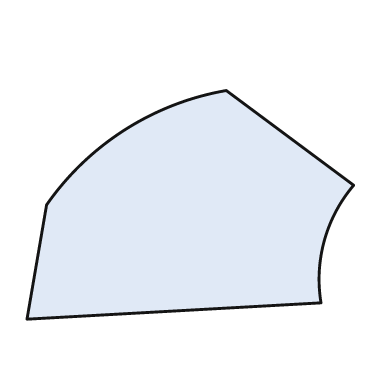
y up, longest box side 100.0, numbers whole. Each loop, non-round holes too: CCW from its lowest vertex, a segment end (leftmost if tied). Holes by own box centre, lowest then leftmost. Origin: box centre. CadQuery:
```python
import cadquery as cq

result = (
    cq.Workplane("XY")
    .moveTo(-50.0, -35.0)
    .lineTo(40.0, -30.0)
    .threePointArc((41.0, -11.0), (50.0, 6.0))
    .lineTo(11.0, 35.0)
    .threePointArc((-20.0, 23.0), (-44.0, 0.0))
    .close()
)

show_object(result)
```